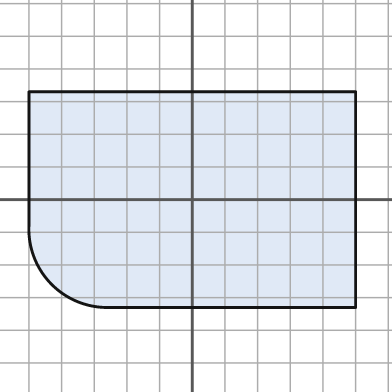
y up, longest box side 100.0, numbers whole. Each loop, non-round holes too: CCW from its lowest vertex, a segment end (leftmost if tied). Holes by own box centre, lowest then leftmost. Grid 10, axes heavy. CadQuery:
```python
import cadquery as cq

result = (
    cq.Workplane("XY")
    .moveTo(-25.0, -33.0)
    .lineTo(50.0, -33.0)
    .lineTo(50.0, 33.0)
    .lineTo(-50.0, 33.0)
    .lineTo(-50.0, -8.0)
    .threePointArc((-43.0, -26.0), (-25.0, -33.0))
    .close()
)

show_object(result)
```